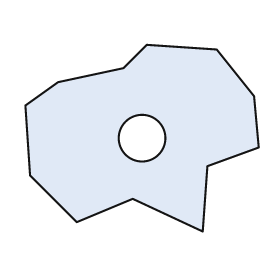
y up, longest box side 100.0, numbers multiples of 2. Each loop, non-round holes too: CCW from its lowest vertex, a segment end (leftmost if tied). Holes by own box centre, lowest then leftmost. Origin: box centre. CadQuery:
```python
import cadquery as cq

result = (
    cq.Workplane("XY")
    .moveTo(26.0, -40.0)
    .lineTo(28.0, -12.0)
    .lineTo(50.0, -4.0)
    .lineTo(48.0, 18.0)
    .lineTo(32.0, 38.0)
    .lineTo(2.0, 40.0)
    .lineTo(-8.0, 30.0)
    .lineTo(-36.0, 24.0)
    .lineTo(-50.0, 14.0)
    .lineTo(-48.0, -16.0)
    .lineTo(-28.0, -36.0)
    .lineTo(-4.0, -26.0)
    .close()
    .moveTo(0.0, 0.0)
    .circle(10.0)
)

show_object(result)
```